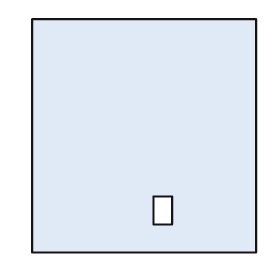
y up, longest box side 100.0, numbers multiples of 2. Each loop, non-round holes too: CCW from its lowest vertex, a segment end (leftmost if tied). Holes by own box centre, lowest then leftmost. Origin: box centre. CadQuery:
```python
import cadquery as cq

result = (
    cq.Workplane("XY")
    .moveTo(-48.0, -50.0)
    .lineTo(48.0, -50.0)
    .lineTo(48.0, 50.0)
    .lineTo(-48.0, 50.0)
    .close()
    .moveTo(4.0, -38.0)
    .lineTo(12.0, -38.0)
    .lineTo(12.0, -26.0)
    .lineTo(4.0, -26.0)
    .close()
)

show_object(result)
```